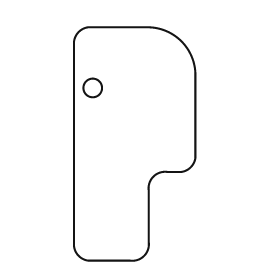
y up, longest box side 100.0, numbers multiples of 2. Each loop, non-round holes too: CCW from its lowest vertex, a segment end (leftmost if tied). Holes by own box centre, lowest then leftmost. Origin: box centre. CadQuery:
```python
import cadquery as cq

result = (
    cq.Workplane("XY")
    .moveTo(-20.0, -50.0)
    .lineTo(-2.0, -50.0)
    .threePointArc((4.0, -48.0), (6.0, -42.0))
    .lineTo(6.0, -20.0)
    .threePointArc((8.0, -14.0), (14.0, -12.0))
    .lineTo(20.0, -12.0)
    .threePointArc((24.0, -10.0), (26.0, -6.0))
    .lineTo(26.0, 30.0)
    .threePointArc((20.0, 44.0), (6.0, 50.0))
    .lineTo(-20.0, 50.0)
    .threePointArc((-24.0, 48.0), (-26.0, 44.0))
    .lineTo(-26.0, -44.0)
    .threePointArc((-24.0, -48.0), (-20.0, -50.0))
    .close()
    .moveTo(-18.0, 24.0)
    .circle(4.0)
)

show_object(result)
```